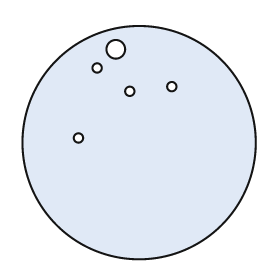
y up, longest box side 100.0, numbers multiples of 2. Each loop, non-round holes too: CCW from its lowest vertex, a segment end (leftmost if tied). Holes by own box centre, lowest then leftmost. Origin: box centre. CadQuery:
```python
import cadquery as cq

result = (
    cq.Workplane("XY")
    .moveTo(0.0, 0.0)
    .circle(50.0)
    .moveTo(-26.0, 2.0)
    .circle(2.0)
    .moveTo(-4.0, 22.0)
    .circle(2.0)
    .moveTo(14.0, 24.0)
    .circle(2.0)
    .moveTo(-18.0, 32.0)
    .circle(2.0)
    .moveTo(-10.0, 40.0)
    .circle(4.0)
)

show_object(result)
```